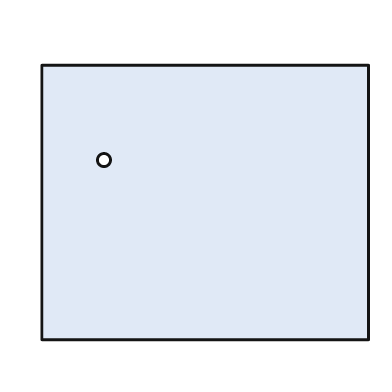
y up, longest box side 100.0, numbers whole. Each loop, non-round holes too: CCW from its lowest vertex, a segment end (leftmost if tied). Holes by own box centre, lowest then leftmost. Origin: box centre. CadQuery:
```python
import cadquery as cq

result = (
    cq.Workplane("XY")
    .moveTo(-50.0, -42.0)
    .lineTo(50.0, -42.0)
    .lineTo(50.0, 42.0)
    .lineTo(-50.0, 42.0)
    .close()
    .moveTo(-31.0, 13.0)
    .circle(2.0)
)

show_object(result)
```